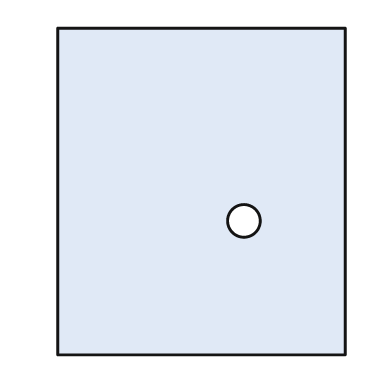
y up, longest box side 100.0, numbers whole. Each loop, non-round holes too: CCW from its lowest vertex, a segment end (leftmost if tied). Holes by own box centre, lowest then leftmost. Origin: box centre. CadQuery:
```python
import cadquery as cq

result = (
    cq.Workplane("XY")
    .moveTo(-44.0, -50.0)
    .lineTo(44.0, -50.0)
    .lineTo(44.0, 50.0)
    .lineTo(-44.0, 50.0)
    .close()
    .moveTo(13.0, -9.0)
    .circle(5.0)
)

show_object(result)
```